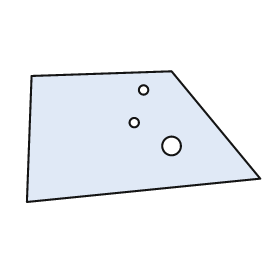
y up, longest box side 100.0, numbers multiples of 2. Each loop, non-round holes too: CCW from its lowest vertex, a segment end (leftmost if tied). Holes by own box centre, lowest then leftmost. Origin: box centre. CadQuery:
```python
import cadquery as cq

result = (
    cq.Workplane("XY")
    .moveTo(-50.0, -28.0)
    .lineTo(50.0, -18.0)
    .lineTo(12.0, 28.0)
    .lineTo(-48.0, 26.0)
    .close()
    .moveTo(12.0, -4.0)
    .circle(4.0)
    .moveTo(-4.0, 6.0)
    .circle(2.0)
    .moveTo(0.0, 20.0)
    .circle(2.0)
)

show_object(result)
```